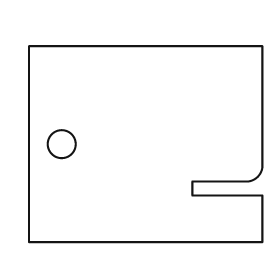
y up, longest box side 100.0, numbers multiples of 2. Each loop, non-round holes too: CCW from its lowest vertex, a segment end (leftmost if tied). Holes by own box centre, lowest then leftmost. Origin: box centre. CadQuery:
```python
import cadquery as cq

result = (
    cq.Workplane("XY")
    .moveTo(-50.0, -42.0)
    .lineTo(50.0, -42.0)
    .lineTo(50.0, -22.0)
    .lineTo(20.0, -22.0)
    .lineTo(20.0, -16.0)
    .lineTo(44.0, -16.0)
    .threePointArc((48.0, -14.0), (50.0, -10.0))
    .lineTo(50.0, 42.0)
    .lineTo(-50.0, 42.0)
    .close()
    .moveTo(-36.0, 0.0)
    .circle(6.0)
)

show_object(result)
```